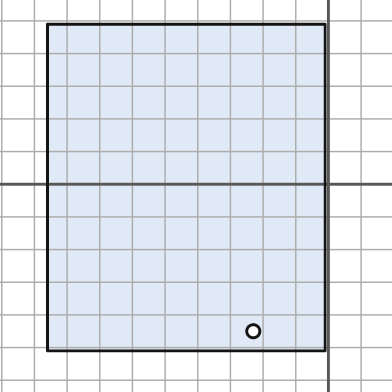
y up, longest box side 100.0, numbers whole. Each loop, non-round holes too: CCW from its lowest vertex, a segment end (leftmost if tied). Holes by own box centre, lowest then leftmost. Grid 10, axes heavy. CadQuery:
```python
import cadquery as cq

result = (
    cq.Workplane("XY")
    .moveTo(-86.0, -51.0)
    .lineTo(-1.0, -51.0)
    .lineTo(-1.0, 49.0)
    .lineTo(-86.0, 49.0)
    .close()
    .moveTo(-23.0, -45.0)
    .circle(2.0)
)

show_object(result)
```